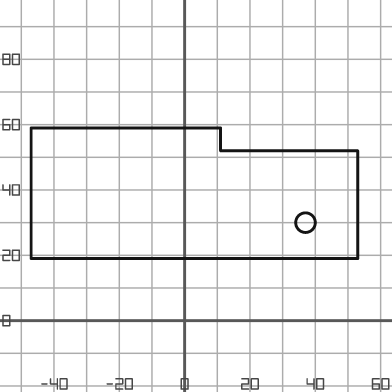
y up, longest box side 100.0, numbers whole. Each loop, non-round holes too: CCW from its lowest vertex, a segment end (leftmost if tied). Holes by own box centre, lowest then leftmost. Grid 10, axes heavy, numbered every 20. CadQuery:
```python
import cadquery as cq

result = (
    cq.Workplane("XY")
    .moveTo(-47.0, 19.0)
    .lineTo(53.0, 19.0)
    .lineTo(53.0, 52.0)
    .lineTo(11.0, 52.0)
    .lineTo(11.0, 59.0)
    .lineTo(-47.0, 59.0)
    .close()
    .moveTo(37.0, 30.0)
    .circle(3.0)
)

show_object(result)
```